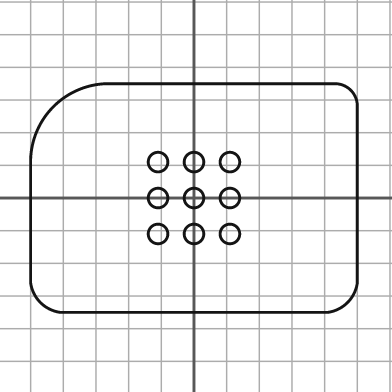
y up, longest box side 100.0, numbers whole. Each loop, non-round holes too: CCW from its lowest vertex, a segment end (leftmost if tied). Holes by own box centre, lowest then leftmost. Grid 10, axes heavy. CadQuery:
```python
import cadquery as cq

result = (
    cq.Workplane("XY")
    .moveTo(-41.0, -35.0)
    .lineTo(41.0, -35.0)
    .threePointArc((47.0, -32.0), (50.0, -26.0))
    .lineTo(50.0, 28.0)
    .threePointArc((48.0, 33.0), (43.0, 35.0))
    .lineTo(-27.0, 35.0)
    .threePointArc((-43.0, 28.0), (-50.0, 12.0))
    .lineTo(-50.0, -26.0)
    .threePointArc((-47.0, -32.0), (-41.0, -35.0))
    .close()
    .moveTo(-11.0, -11.0)
    .circle(3.0)
    .moveTo(0.0, -11.0)
    .circle(3.0)
    .moveTo(11.0, -11.0)
    .circle(3.0)
    .moveTo(-11.0, 0.0)
    .circle(3.0)
    .moveTo(0.0, 0.0)
    .circle(3.0)
    .moveTo(11.0, 0.0)
    .circle(3.0)
    .moveTo(-11.0, 11.0)
    .circle(3.0)
    .moveTo(0.0, 11.0)
    .circle(3.0)
    .moveTo(11.0, 11.0)
    .circle(3.0)
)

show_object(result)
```